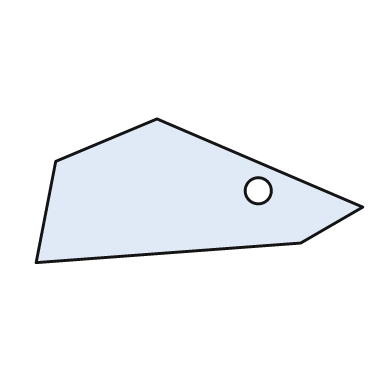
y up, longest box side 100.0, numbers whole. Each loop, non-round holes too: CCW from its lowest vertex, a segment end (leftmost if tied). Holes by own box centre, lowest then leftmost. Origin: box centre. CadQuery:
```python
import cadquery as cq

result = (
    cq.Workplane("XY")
    .moveTo(-50.0, -22.0)
    .lineTo(31.0, -16.0)
    .lineTo(50.0, -5.0)
    .lineTo(-13.0, 22.0)
    .lineTo(-44.0, 9.0)
    .close()
    .moveTo(18.0, 0.0)
    .circle(4.0)
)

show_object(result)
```